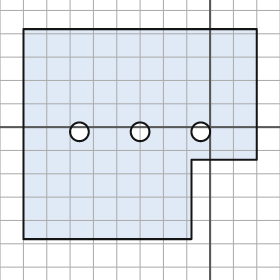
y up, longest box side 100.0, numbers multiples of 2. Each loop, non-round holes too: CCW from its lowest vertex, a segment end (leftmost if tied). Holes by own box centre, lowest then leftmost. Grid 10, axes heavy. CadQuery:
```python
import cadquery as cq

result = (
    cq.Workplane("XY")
    .moveTo(-80.0, -48.0)
    .lineTo(-8.0, -48.0)
    .lineTo(-8.0, -14.0)
    .lineTo(20.0, -14.0)
    .lineTo(20.0, 42.0)
    .lineTo(-80.0, 42.0)
    .close()
    .moveTo(-56.0, -2.0)
    .circle(4.0)
    .moveTo(-30.0, -2.0)
    .circle(4.0)
    .moveTo(-4.0, -2.0)
    .circle(4.0)
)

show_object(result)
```